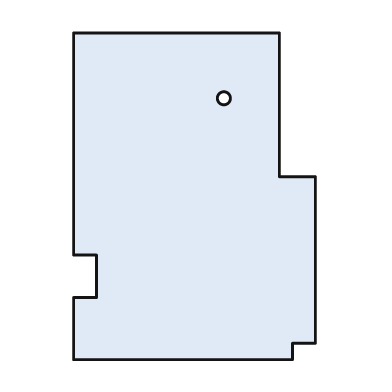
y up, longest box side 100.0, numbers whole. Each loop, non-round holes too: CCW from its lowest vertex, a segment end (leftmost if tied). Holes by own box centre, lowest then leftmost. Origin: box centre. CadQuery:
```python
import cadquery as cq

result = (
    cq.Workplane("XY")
    .moveTo(-37.0, -50.0)
    .lineTo(30.0, -50.0)
    .lineTo(30.0, -45.0)
    .lineTo(37.0, -45.0)
    .lineTo(37.0, 6.0)
    .lineTo(26.0, 6.0)
    .lineTo(26.0, 50.0)
    .lineTo(-37.0, 50.0)
    .lineTo(-37.0, -18.0)
    .lineTo(-30.0, -18.0)
    .lineTo(-30.0, -31.0)
    .lineTo(-37.0, -31.0)
    .close()
    .moveTo(9.0, 30.0)
    .circle(2.0)
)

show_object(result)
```